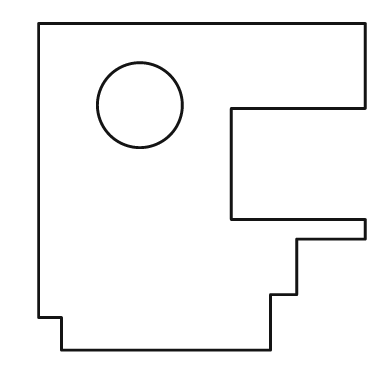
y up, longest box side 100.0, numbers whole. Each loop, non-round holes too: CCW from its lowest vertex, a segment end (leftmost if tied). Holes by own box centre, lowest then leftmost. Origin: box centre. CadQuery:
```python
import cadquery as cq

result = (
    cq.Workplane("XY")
    .moveTo(-43.0, -50.0)
    .lineTo(21.0, -50.0)
    .lineTo(21.0, -33.0)
    .lineTo(29.0, -33.0)
    .lineTo(29.0, -16.0)
    .lineTo(50.0, -16.0)
    .lineTo(50.0, -10.0)
    .lineTo(9.0, -10.0)
    .lineTo(9.0, 24.0)
    .lineTo(50.0, 24.0)
    .lineTo(50.0, 50.0)
    .lineTo(-50.0, 50.0)
    .lineTo(-50.0, -40.0)
    .lineTo(-43.0, -40.0)
    .close()
    .moveTo(-19.0, 25.0)
    .circle(13.0)
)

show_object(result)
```